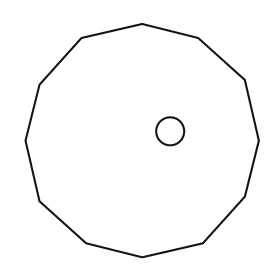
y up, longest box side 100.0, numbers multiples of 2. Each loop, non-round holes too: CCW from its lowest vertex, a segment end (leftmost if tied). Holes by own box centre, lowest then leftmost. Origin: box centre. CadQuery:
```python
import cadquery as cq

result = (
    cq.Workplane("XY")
    .moveTo(0.0, -50.0)
    .lineTo(26.0, -44.0)
    .lineTo(44.0, -24.0)
    .lineTo(50.0, 0.0)
    .lineTo(44.0, 26.0)
    .lineTo(24.0, 44.0)
    .lineTo(0.0, 50.0)
    .lineTo(-26.0, 44.0)
    .lineTo(-44.0, 24.0)
    .lineTo(-50.0, 0.0)
    .lineTo(-44.0, -26.0)
    .lineTo(-24.0, -44.0)
    .close()
    .moveTo(12.0, 4.0)
    .circle(6.0)
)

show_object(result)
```